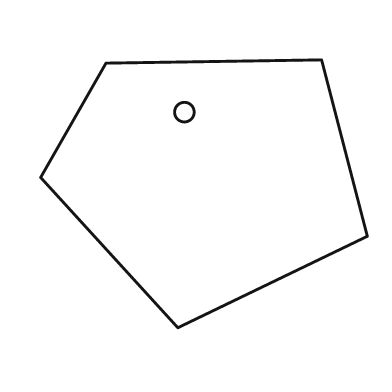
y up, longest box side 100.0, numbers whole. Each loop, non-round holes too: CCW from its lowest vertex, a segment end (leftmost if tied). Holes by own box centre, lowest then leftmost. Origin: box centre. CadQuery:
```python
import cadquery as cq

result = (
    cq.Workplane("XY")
    .moveTo(-8.0, -41.0)
    .lineTo(50.0, -13.0)
    .lineTo(36.0, 41.0)
    .lineTo(-30.0, 40.0)
    .lineTo(-50.0, 5.0)
    .close()
    .moveTo(-6.0, 25.0)
    .circle(3.0)
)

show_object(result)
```